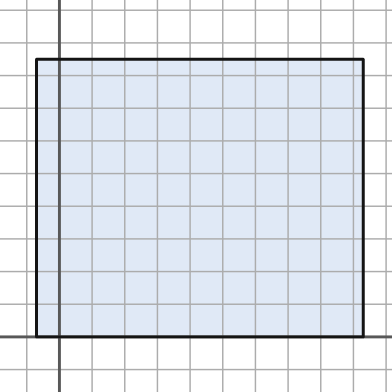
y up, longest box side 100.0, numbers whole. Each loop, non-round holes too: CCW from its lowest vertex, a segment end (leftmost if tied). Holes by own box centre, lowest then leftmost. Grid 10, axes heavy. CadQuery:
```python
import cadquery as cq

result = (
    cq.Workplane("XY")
    .moveTo(-7.0, 0.0)
    .lineTo(93.0, 0.0)
    .lineTo(93.0, 85.0)
    .lineTo(-7.0, 85.0)
    .close()
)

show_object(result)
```